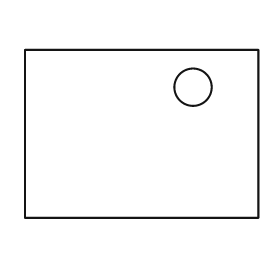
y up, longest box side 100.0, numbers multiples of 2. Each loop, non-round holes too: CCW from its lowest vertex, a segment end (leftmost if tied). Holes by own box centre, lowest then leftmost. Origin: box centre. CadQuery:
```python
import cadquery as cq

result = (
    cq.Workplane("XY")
    .moveTo(-50.0, -36.0)
    .lineTo(50.0, -36.0)
    .lineTo(50.0, 36.0)
    .lineTo(-50.0, 36.0)
    .close()
    .moveTo(22.0, 20.0)
    .circle(8.0)
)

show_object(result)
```